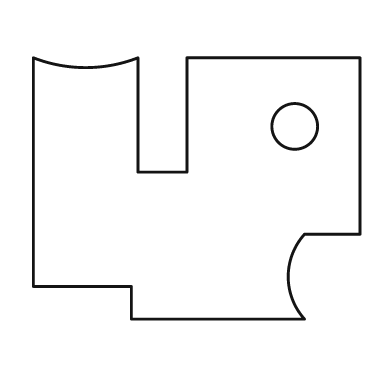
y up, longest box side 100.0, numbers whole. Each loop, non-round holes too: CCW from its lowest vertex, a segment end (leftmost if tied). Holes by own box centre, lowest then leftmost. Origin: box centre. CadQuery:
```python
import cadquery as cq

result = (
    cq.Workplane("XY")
    .moveTo(-20.0, -40.0)
    .lineTo(33.0, -40.0)
    .threePointArc((28.0, -27.0), (33.0, -14.0))
    .lineTo(50.0, -14.0)
    .lineTo(50.0, 40.0)
    .lineTo(-3.0, 40.0)
    .lineTo(-3.0, 5.0)
    .lineTo(-18.0, 5.0)
    .lineTo(-18.0, 40.0)
    .threePointArc((-34.0, 37.0), (-50.0, 40.0))
    .lineTo(-50.0, -30.0)
    .lineTo(-20.0, -30.0)
    .close()
    .moveTo(30.0, 19.0)
    .circle(7.0)
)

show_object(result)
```